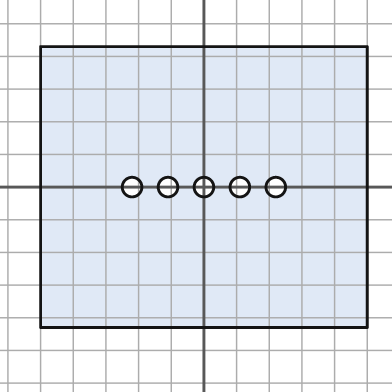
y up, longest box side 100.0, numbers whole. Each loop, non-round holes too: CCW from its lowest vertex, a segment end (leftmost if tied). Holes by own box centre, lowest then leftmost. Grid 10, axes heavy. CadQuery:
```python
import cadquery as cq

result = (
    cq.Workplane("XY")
    .moveTo(-50.0, -43.0)
    .lineTo(50.0, -43.0)
    .lineTo(50.0, 43.0)
    .lineTo(-50.0, 43.0)
    .close()
    .moveTo(-22.0, 0.0)
    .circle(3.0)
    .moveTo(-11.0, 0.0)
    .circle(3.0)
    .moveTo(0.0, 0.0)
    .circle(3.0)
    .moveTo(11.0, 0.0)
    .circle(3.0)
    .moveTo(22.0, 0.0)
    .circle(3.0)
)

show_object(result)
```